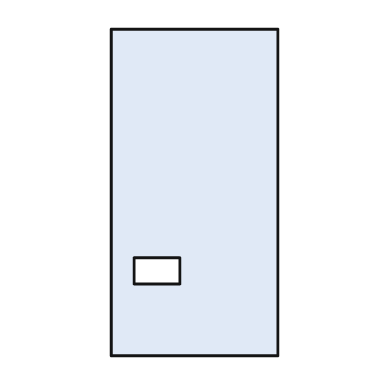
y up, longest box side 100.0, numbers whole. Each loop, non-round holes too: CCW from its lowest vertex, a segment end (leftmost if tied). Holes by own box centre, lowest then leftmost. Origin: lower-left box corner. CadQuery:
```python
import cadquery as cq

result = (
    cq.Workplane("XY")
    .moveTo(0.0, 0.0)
    .lineTo(51.0, 0.0)
    .lineTo(51.0, 100.0)
    .lineTo(0.0, 100.0)
    .close()
    .moveTo(7.0, 22.0)
    .lineTo(21.0, 22.0)
    .lineTo(21.0, 30.0)
    .lineTo(7.0, 30.0)
    .close()
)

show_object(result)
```